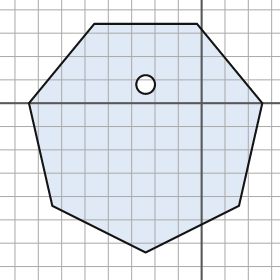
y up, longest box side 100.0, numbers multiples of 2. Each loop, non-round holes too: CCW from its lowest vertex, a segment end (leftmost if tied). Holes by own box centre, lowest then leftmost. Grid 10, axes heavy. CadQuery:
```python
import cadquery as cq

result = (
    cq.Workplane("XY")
    .moveTo(-24.0, -64.0)
    .lineTo(16.0, -44.0)
    .lineTo(26.0, 0.0)
    .lineTo(-2.0, 34.0)
    .lineTo(-46.0, 34.0)
    .lineTo(-74.0, 0.0)
    .lineTo(-64.0, -44.0)
    .close()
    .moveTo(-24.0, 8.0)
    .circle(4.0)
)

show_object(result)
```